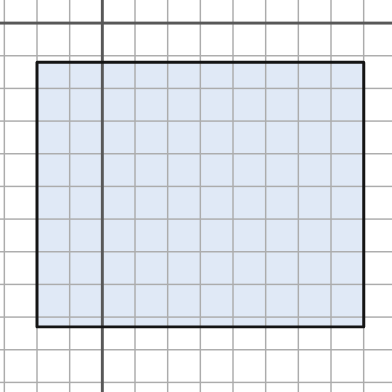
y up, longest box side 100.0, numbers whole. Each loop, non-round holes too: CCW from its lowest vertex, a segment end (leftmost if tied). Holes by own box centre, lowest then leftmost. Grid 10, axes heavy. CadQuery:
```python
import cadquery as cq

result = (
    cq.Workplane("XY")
    .moveTo(-20.0, -93.0)
    .lineTo(80.0, -93.0)
    .lineTo(80.0, -12.0)
    .lineTo(-20.0, -12.0)
    .close()
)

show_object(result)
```